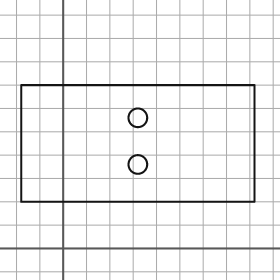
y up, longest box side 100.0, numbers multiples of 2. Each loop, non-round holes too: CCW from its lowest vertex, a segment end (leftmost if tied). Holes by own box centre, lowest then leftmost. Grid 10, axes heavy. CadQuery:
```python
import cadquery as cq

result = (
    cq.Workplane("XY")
    .moveTo(-18.0, 20.0)
    .lineTo(82.0, 20.0)
    .lineTo(82.0, 70.0)
    .lineTo(-18.0, 70.0)
    .close()
    .moveTo(32.0, 36.0)
    .circle(4.0)
    .moveTo(32.0, 56.0)
    .circle(4.0)
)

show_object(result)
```